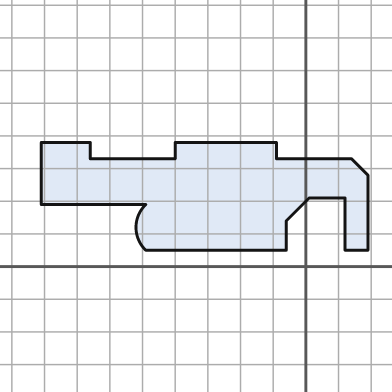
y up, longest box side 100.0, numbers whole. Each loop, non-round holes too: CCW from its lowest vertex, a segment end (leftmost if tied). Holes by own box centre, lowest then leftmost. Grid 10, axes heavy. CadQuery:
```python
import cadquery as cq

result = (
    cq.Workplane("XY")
    .moveTo(-49.0, 5.0)
    .lineTo(-6.0, 5.0)
    .lineTo(-6.0, 14.0)
    .lineTo(1.0, 21.0)
    .lineTo(12.0, 21.0)
    .lineTo(12.0, 5.0)
    .lineTo(19.0, 5.0)
    .lineTo(19.0, 28.0)
    .lineTo(14.0, 33.0)
    .lineTo(-9.0, 33.0)
    .lineTo(-9.0, 38.0)
    .lineTo(-40.0, 38.0)
    .lineTo(-40.0, 33.0)
    .lineTo(-66.0, 33.0)
    .lineTo(-66.0, 38.0)
    .lineTo(-81.0, 38.0)
    .lineTo(-81.0, 19.0)
    .lineTo(-49.0, 19.0)
    .threePointArc((-52.0, 12.0), (-49.0, 5.0))
    .close()
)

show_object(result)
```